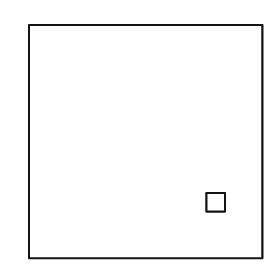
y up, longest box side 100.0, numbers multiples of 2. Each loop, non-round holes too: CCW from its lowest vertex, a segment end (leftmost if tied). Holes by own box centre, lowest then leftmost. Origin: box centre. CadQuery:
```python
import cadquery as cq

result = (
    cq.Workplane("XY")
    .moveTo(-50.0, -50.0)
    .lineTo(50.0, -50.0)
    .lineTo(50.0, 50.0)
    .lineTo(-50.0, 50.0)
    .close()
    .moveTo(26.0, -30.0)
    .lineTo(34.0, -30.0)
    .lineTo(34.0, -22.0)
    .lineTo(26.0, -22.0)
    .close()
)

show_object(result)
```